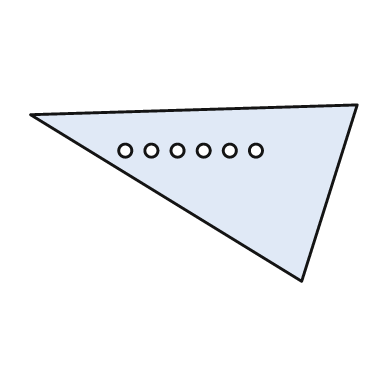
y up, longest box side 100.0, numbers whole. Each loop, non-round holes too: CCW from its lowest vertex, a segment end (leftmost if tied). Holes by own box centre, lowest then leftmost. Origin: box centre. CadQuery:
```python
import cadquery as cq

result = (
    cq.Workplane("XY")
    .moveTo(33.0, -27.0)
    .lineTo(50.0, 27.0)
    .lineTo(-50.0, 24.0)
    .close()
    .moveTo(-21.0, 13.0)
    .circle(2.0)
    .moveTo(-13.0, 13.0)
    .circle(2.0)
    .moveTo(-5.0, 13.0)
    .circle(2.0)
    .moveTo(3.0, 13.0)
    .circle(2.0)
    .moveTo(11.0, 13.0)
    .circle(2.0)
    .moveTo(19.0, 13.0)
    .circle(2.0)
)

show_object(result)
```